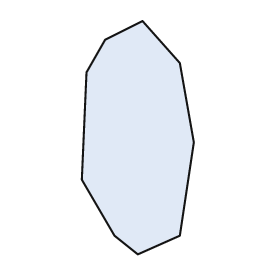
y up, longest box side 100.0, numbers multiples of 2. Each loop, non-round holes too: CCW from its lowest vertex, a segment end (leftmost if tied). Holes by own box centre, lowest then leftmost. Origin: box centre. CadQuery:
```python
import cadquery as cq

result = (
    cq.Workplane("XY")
    .moveTo(0.0, -50.0)
    .lineTo(18.0, -42.0)
    .lineTo(24.0, -2.0)
    .lineTo(18.0, 32.0)
    .lineTo(2.0, 50.0)
    .lineTo(-14.0, 42.0)
    .lineTo(-22.0, 28.0)
    .lineTo(-24.0, -18.0)
    .lineTo(-10.0, -42.0)
    .close()
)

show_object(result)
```